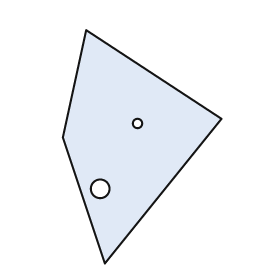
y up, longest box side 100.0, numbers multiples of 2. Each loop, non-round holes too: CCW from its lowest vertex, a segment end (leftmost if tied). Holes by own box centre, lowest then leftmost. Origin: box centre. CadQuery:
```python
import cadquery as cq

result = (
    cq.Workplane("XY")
    .moveTo(-16.0, -50.0)
    .lineTo(34.0, 12.0)
    .lineTo(-24.0, 50.0)
    .lineTo(-34.0, 4.0)
    .close()
    .moveTo(-18.0, -18.0)
    .circle(4.0)
    .moveTo(-2.0, 10.0)
    .circle(2.0)
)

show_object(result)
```